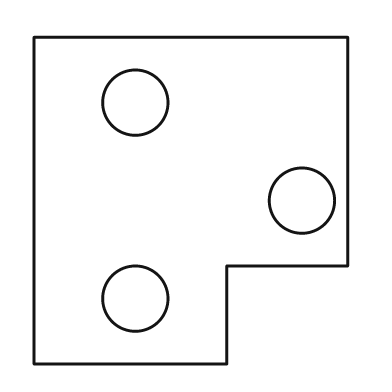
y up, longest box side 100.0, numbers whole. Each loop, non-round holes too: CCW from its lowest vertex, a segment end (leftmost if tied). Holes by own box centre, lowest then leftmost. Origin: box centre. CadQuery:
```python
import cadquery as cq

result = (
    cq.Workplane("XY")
    .moveTo(-48.0, -50.0)
    .lineTo(11.0, -50.0)
    .lineTo(11.0, -20.0)
    .lineTo(48.0, -20.0)
    .lineTo(48.0, 50.0)
    .lineTo(-48.0, 50.0)
    .close()
    .moveTo(-17.0, -30.0)
    .circle(10.0)
    .moveTo(34.0, 0.0)
    .circle(10.0)
    .moveTo(-17.0, 30.0)
    .circle(10.0)
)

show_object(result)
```